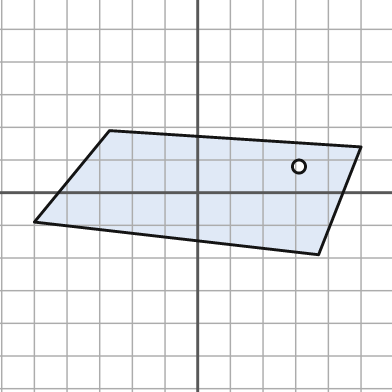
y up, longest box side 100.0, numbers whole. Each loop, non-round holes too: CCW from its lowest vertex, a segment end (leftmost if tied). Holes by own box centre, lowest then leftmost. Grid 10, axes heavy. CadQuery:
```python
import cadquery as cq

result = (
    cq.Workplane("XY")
    .moveTo(37.0, -19.0)
    .lineTo(50.0, 14.0)
    .lineTo(-27.0, 19.0)
    .lineTo(-50.0, -9.0)
    .close()
    .moveTo(31.0, 8.0)
    .circle(2.0)
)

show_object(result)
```